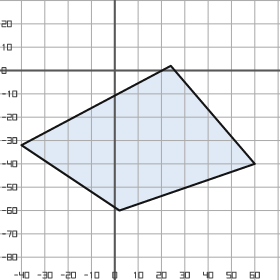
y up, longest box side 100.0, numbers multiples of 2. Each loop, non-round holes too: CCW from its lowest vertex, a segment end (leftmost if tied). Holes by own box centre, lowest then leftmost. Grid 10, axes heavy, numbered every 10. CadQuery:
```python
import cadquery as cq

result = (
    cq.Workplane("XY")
    .moveTo(2.0, -60.0)
    .lineTo(60.0, -40.0)
    .lineTo(24.0, 2.0)
    .lineTo(-40.0, -32.0)
    .close()
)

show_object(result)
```